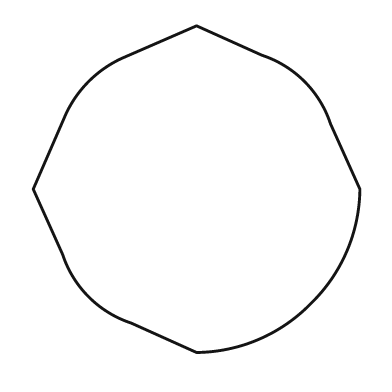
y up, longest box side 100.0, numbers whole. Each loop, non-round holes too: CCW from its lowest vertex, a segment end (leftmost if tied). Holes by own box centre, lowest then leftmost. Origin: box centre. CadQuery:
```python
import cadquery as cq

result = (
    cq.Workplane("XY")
    .moveTo(0.0, -50.0)
    .threePointArc((19.0, -46.0), (35.0, -35.0))
    .threePointArc((46.0, -19.0), (50.0, 0.0))
    .lineTo(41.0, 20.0)
    .threePointArc((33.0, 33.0), (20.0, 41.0))
    .lineTo(0.0, 50.0)
    .lineTo(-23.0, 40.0)
    .threePointArc((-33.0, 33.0), (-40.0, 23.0))
    .lineTo(-50.0, 0.0)
    .lineTo(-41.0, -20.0)
    .threePointArc((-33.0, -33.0), (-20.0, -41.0))
    .close()
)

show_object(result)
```